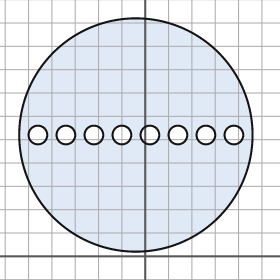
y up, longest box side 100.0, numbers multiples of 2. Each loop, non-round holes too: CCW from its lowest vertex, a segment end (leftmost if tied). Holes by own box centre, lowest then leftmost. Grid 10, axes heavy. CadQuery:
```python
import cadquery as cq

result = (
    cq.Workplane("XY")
    .moveTo(-4.0, 52.0)
    .circle(50.0)
    .moveTo(-46.0, 52.0)
    .circle(4.0)
    .moveTo(-34.0, 52.0)
    .circle(4.0)
    .moveTo(-22.0, 52.0)
    .circle(4.0)
    .moveTo(-10.0, 52.0)
    .circle(4.0)
    .moveTo(2.0, 52.0)
    .circle(4.0)
    .moveTo(14.0, 52.0)
    .circle(4.0)
    .moveTo(26.0, 52.0)
    .circle(4.0)
    .moveTo(38.0, 52.0)
    .circle(4.0)
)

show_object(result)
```